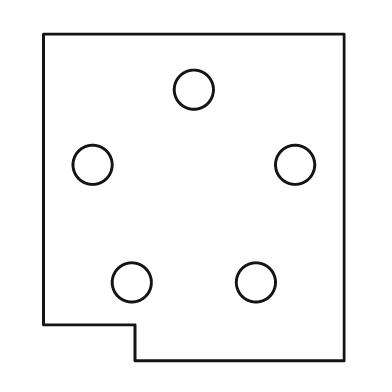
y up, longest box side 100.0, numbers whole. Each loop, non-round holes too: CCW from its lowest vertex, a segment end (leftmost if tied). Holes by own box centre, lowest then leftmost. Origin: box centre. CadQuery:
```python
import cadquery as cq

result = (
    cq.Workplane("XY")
    .moveTo(-18.0, -50.0)
    .lineTo(46.0, -50.0)
    .lineTo(46.0, 50.0)
    .lineTo(-46.0, 50.0)
    .lineTo(-46.0, -39.0)
    .lineTo(-18.0, -39.0)
    .close()
    .moveTo(-19.0, -26.0)
    .circle(6.0)
    .moveTo(19.0, -26.0)
    .circle(6.0)
    .moveTo(-31.0, 10.0)
    .circle(6.0)
    .moveTo(31.0, 10.0)
    .circle(6.0)
    .moveTo(0.0, 33.0)
    .circle(6.0)
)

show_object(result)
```